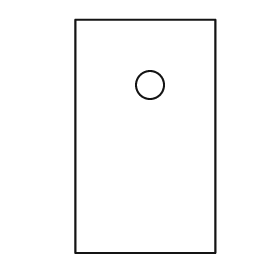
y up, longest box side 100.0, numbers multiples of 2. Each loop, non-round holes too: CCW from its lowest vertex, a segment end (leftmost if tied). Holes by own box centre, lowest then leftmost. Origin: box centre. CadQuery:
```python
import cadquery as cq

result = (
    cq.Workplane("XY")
    .moveTo(-30.0, -50.0)
    .lineTo(30.0, -50.0)
    .lineTo(30.0, 50.0)
    .lineTo(-30.0, 50.0)
    .close()
    .moveTo(2.0, 22.0)
    .circle(6.0)
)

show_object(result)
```